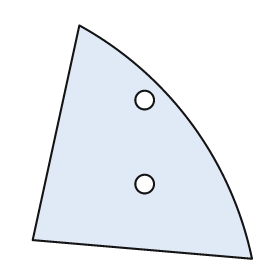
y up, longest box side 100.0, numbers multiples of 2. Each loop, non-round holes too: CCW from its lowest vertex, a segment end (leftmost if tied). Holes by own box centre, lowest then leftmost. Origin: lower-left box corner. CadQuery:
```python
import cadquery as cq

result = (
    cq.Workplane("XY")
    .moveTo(94.0, 0.0)
    .threePointArc((68.0, 58.0), (20.0, 100.0))
    .lineTo(0.0, 8.0)
    .close()
    .moveTo(48.0, 32.0)
    .circle(4.0)
    .moveTo(48.0, 68.0)
    .circle(4.0)
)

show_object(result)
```